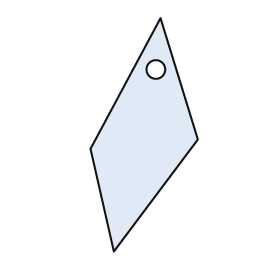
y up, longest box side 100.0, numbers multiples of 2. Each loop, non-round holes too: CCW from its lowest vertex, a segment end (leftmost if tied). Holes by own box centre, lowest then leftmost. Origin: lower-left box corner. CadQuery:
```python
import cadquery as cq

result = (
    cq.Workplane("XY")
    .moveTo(10.0, 0.0)
    .lineTo(46.0, 48.0)
    .lineTo(30.0, 100.0)
    .lineTo(0.0, 44.0)
    .close()
    .moveTo(28.0, 78.0)
    .circle(4.0)
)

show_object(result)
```